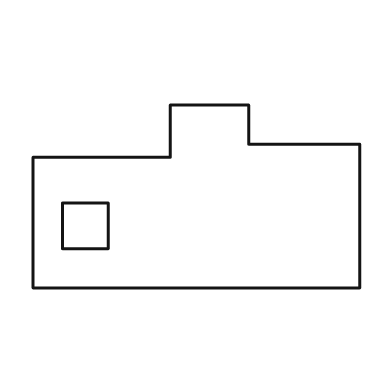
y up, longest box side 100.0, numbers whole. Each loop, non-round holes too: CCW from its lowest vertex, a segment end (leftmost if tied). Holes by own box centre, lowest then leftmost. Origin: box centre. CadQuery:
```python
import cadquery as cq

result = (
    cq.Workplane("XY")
    .moveTo(-50.0, -28.0)
    .lineTo(50.0, -28.0)
    .lineTo(50.0, 16.0)
    .lineTo(16.0, 16.0)
    .lineTo(16.0, 28.0)
    .lineTo(-8.0, 28.0)
    .lineTo(-8.0, 12.0)
    .lineTo(-50.0, 12.0)
    .close()
    .moveTo(-41.0, -16.0)
    .lineTo(-27.0, -16.0)
    .lineTo(-27.0, -2.0)
    .lineTo(-41.0, -2.0)
    .close()
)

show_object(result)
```